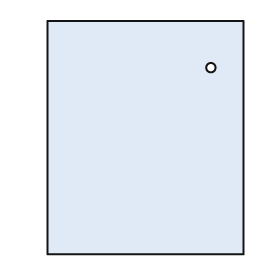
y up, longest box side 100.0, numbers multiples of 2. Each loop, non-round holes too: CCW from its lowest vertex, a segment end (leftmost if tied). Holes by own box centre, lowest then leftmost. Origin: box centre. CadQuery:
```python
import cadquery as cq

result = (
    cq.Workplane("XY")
    .moveTo(-42.0, -50.0)
    .lineTo(42.0, -50.0)
    .lineTo(42.0, 50.0)
    .lineTo(-42.0, 50.0)
    .close()
    .moveTo(28.0, 30.0)
    .circle(2.0)
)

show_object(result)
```